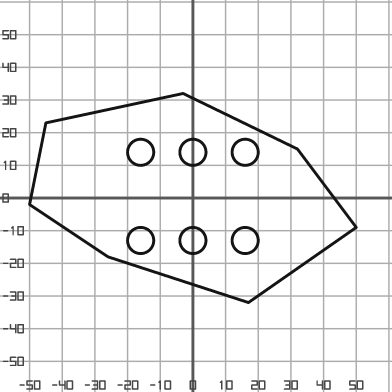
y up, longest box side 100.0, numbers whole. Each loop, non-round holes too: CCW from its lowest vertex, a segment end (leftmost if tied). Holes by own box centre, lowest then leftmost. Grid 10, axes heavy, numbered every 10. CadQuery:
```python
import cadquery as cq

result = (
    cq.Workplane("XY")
    .moveTo(17.0, -32.0)
    .lineTo(50.0, -9.0)
    .lineTo(32.0, 15.0)
    .lineTo(-3.0, 32.0)
    .lineTo(-45.0, 23.0)
    .lineTo(-50.0, -2.0)
    .lineTo(-26.0, -18.0)
    .close()
    .moveTo(-16.0, -13.0)
    .circle(4.0)
    .moveTo(0.0, -13.0)
    .circle(4.0)
    .moveTo(16.0, -13.0)
    .circle(4.0)
    .moveTo(-16.0, 14.0)
    .circle(4.0)
    .moveTo(0.0, 14.0)
    .circle(4.0)
    .moveTo(16.0, 14.0)
    .circle(4.0)
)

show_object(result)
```